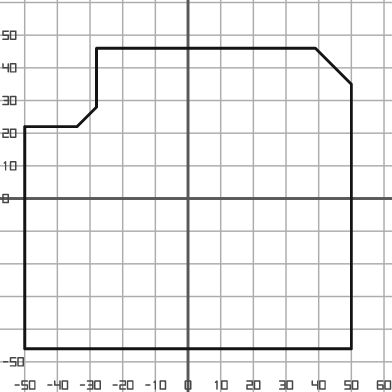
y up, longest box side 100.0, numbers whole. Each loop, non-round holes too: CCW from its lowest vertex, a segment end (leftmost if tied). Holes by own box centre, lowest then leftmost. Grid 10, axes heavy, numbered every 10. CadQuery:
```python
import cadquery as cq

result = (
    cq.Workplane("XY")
    .moveTo(-50.0, -46.0)
    .lineTo(50.0, -46.0)
    .lineTo(50.0, 35.0)
    .lineTo(39.0, 46.0)
    .lineTo(-28.0, 46.0)
    .lineTo(-28.0, 28.0)
    .lineTo(-34.0, 22.0)
    .lineTo(-50.0, 22.0)
    .close()
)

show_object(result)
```